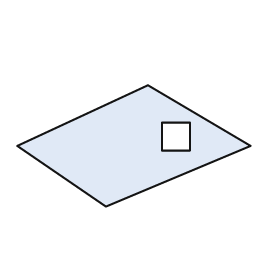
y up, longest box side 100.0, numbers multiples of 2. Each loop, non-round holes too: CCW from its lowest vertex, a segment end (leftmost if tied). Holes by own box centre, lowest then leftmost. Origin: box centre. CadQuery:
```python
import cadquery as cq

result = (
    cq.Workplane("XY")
    .moveTo(-12.0, -26.0)
    .lineTo(50.0, 0.0)
    .lineTo(6.0, 26.0)
    .lineTo(-50.0, 0.0)
    .close()
    .moveTo(12.0, -2.0)
    .lineTo(24.0, -2.0)
    .lineTo(24.0, 10.0)
    .lineTo(12.0, 10.0)
    .close()
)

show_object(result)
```